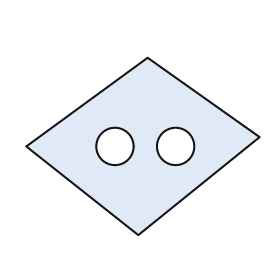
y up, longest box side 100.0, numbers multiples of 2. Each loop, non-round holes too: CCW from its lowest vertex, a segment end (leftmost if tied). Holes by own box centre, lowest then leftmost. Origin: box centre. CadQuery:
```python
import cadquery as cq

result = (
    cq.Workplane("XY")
    .moveTo(-2.0, -38.0)
    .lineTo(50.0, 4.0)
    .lineTo(2.0, 38.0)
    .lineTo(-50.0, 0.0)
    .close()
    .moveTo(-12.0, 0.0)
    .circle(8.0)
    .moveTo(14.0, 0.0)
    .circle(8.0)
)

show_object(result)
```